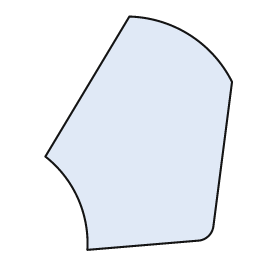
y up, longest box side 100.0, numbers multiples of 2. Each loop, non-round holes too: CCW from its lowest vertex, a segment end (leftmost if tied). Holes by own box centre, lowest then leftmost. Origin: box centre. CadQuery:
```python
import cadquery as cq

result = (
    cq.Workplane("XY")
    .moveTo(-22.0, -50.0)
    .lineTo(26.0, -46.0)
    .threePointArc((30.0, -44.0), (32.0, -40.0))
    .lineTo(40.0, 22.0)
    .threePointArc((22.0, 42.0), (-4.0, 50.0))
    .lineTo(-40.0, -10.0)
    .threePointArc((-26.0, -28.0), (-22.0, -50.0))
    .close()
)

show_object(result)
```